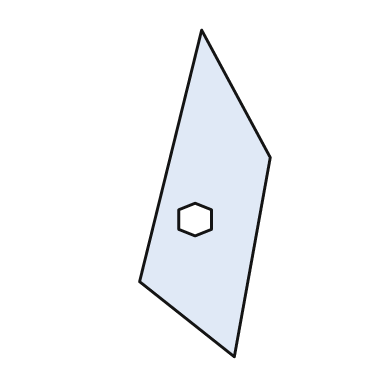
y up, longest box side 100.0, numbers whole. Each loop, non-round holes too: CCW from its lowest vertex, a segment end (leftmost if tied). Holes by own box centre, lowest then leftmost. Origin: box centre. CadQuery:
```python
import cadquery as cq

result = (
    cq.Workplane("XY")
    .moveTo(9.0, -50.0)
    .lineTo(20.0, 11.0)
    .lineTo(-1.0, 50.0)
    .lineTo(-20.0, -27.0)
    .close()
    .moveTo(-3.0, -13.0)
    .lineTo(2.0, -11.0)
    .lineTo(2.0, -5.0)
    .lineTo(-3.0, -3.0)
    .lineTo(-8.0, -5.0)
    .lineTo(-8.0, -11.0)
    .close()
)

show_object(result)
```